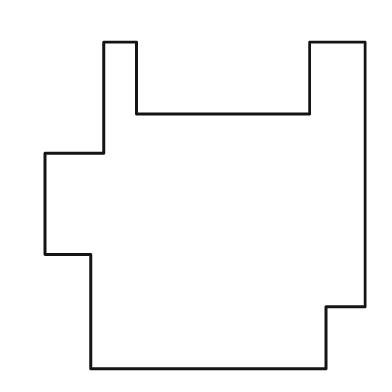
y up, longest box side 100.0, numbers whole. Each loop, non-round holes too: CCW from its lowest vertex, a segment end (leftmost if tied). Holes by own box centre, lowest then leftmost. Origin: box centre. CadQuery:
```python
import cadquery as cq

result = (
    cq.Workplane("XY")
    .moveTo(-35.0, -50.0)
    .lineTo(37.0, -50.0)
    .lineTo(37.0, -31.0)
    .lineTo(49.0, -31.0)
    .lineTo(49.0, 50.0)
    .lineTo(32.0, 50.0)
    .lineTo(32.0, 28.0)
    .lineTo(-21.0, 28.0)
    .lineTo(-21.0, 50.0)
    .lineTo(-31.0, 50.0)
    .lineTo(-31.0, 16.0)
    .lineTo(-49.0, 16.0)
    .lineTo(-49.0, -15.0)
    .lineTo(-35.0, -15.0)
    .close()
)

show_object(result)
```